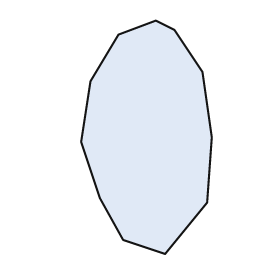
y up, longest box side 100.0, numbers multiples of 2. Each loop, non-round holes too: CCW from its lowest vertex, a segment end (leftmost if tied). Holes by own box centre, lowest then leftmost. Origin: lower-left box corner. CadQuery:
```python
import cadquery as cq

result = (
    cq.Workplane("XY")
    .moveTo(36.0, 0.0)
    .lineTo(54.0, 22.0)
    .lineTo(56.0, 50.0)
    .lineTo(52.0, 78.0)
    .lineTo(40.0, 96.0)
    .lineTo(32.0, 100.0)
    .lineTo(16.0, 94.0)
    .lineTo(4.0, 74.0)
    .lineTo(0.0, 48.0)
    .lineTo(8.0, 24.0)
    .lineTo(18.0, 6.0)
    .close()
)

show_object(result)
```